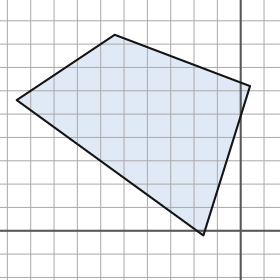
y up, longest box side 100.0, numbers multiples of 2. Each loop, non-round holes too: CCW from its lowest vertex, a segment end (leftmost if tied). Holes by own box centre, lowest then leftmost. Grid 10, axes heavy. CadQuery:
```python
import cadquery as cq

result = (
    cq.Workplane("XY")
    .moveTo(-16.0, -2.0)
    .lineTo(4.0, 62.0)
    .lineTo(-54.0, 84.0)
    .lineTo(-96.0, 56.0)
    .close()
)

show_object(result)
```